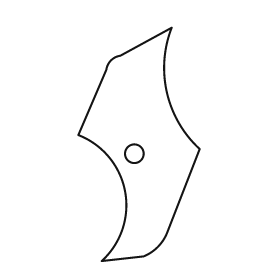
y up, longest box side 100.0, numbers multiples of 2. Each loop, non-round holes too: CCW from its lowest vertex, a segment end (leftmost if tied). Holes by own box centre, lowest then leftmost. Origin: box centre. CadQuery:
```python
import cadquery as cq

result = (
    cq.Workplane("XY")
    .moveTo(-16.0, -50.0)
    .lineTo(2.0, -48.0)
    .threePointArc((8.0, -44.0), (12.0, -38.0))
    .lineTo(26.0, -2.0)
    .threePointArc((12.0, 22.0), (14.0, 50.0))
    .lineTo(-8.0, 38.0)
    .threePointArc((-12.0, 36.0), (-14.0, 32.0))
    .lineTo(-26.0, 4.0)
    .threePointArc((-6.0, -20.0), (-16.0, -50.0))
    .close()
    .moveTo(-2.0, -4.0)
    .circle(4.0)
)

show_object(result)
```